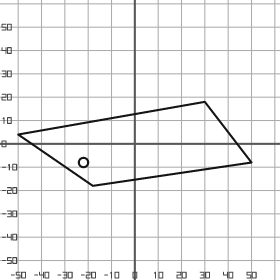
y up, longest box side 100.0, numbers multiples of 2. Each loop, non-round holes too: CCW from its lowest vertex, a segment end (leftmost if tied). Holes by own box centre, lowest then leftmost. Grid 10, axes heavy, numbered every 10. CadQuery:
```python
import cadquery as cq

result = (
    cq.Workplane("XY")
    .moveTo(-18.0, -18.0)
    .lineTo(50.0, -8.0)
    .lineTo(30.0, 18.0)
    .lineTo(-50.0, 4.0)
    .close()
    .moveTo(-22.0, -8.0)
    .circle(2.0)
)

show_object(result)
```